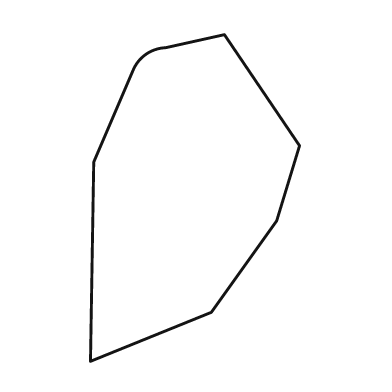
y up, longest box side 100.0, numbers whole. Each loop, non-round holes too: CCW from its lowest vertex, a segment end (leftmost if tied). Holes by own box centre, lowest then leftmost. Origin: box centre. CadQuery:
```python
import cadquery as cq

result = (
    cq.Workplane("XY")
    .moveTo(-32.0, -50.0)
    .lineTo(5.0, -35.0)
    .lineTo(25.0, -7.0)
    .lineTo(32.0, 16.0)
    .lineTo(9.0, 50.0)
    .lineTo(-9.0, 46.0)
    .threePointArc((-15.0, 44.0), (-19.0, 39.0))
    .lineTo(-31.0, 11.0)
    .close()
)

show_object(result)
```